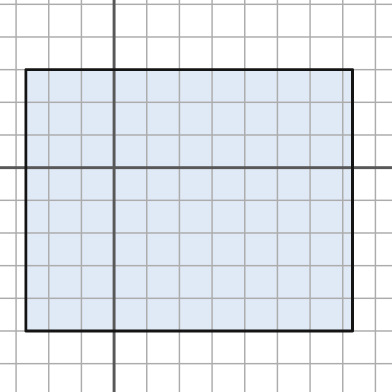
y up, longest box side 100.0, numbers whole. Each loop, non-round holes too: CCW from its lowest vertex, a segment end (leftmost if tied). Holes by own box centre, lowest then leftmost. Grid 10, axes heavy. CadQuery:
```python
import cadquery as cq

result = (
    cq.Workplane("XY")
    .moveTo(-27.0, -50.0)
    .lineTo(73.0, -50.0)
    .lineTo(73.0, 30.0)
    .lineTo(-27.0, 30.0)
    .close()
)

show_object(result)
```